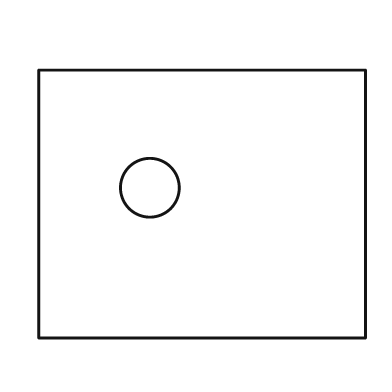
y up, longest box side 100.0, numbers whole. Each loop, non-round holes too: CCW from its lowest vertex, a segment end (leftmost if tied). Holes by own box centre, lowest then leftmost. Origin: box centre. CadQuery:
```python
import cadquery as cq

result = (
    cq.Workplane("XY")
    .moveTo(-50.0, -41.0)
    .lineTo(50.0, -41.0)
    .lineTo(50.0, 41.0)
    .lineTo(-50.0, 41.0)
    .close()
    .moveTo(-16.0, 5.0)
    .circle(9.0)
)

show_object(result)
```